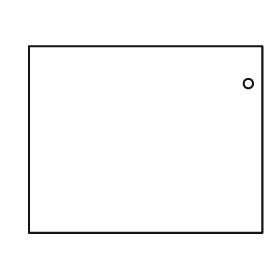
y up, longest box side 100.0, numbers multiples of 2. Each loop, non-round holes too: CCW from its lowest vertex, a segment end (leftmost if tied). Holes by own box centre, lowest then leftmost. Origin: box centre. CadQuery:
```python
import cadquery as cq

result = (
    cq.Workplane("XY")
    .moveTo(-50.0, -40.0)
    .lineTo(50.0, -40.0)
    .lineTo(50.0, 40.0)
    .lineTo(-50.0, 40.0)
    .close()
    .moveTo(44.0, 24.0)
    .circle(2.0)
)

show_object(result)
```